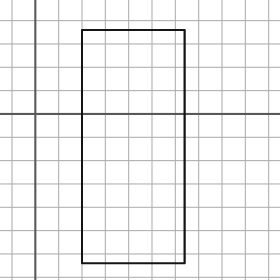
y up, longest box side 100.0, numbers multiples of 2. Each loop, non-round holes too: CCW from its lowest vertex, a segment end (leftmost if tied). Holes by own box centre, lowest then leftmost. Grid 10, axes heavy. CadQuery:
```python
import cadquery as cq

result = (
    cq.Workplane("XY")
    .moveTo(20.0, -64.0)
    .lineTo(64.0, -64.0)
    .lineTo(64.0, 36.0)
    .lineTo(20.0, 36.0)
    .close()
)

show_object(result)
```